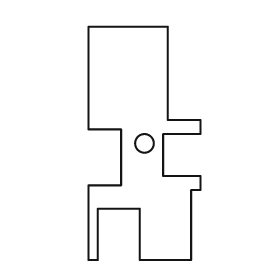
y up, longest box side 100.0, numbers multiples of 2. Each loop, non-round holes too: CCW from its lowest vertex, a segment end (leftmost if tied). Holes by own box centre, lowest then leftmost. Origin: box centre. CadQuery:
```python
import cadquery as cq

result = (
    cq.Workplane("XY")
    .moveTo(-24.0, -50.0)
    .lineTo(-20.0, -50.0)
    .lineTo(-20.0, -28.0)
    .lineTo(-2.0, -28.0)
    .lineTo(-2.0, -50.0)
    .lineTo(20.0, -50.0)
    .lineTo(20.0, -20.0)
    .lineTo(24.0, -20.0)
    .lineTo(24.0, -14.0)
    .lineTo(8.0, -14.0)
    .lineTo(8.0, 4.0)
    .lineTo(24.0, 4.0)
    .lineTo(24.0, 10.0)
    .lineTo(10.0, 10.0)
    .lineTo(10.0, 50.0)
    .lineTo(-24.0, 50.0)
    .lineTo(-24.0, 6.0)
    .lineTo(-10.0, 6.0)
    .lineTo(-10.0, -18.0)
    .lineTo(-24.0, -18.0)
    .close()
    .moveTo(0.0, 0.0)
    .circle(4.0)
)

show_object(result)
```